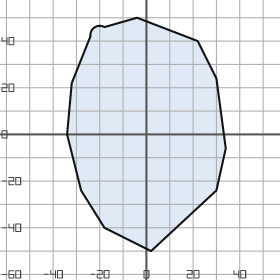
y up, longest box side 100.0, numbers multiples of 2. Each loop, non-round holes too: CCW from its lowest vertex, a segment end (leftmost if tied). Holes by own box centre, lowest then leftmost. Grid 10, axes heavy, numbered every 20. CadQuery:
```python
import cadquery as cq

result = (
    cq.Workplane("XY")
    .moveTo(2.0, -50.0)
    .lineTo(30.0, -24.0)
    .lineTo(34.0, -6.0)
    .lineTo(30.0, 24.0)
    .lineTo(22.0, 40.0)
    .lineTo(-4.0, 50.0)
    .lineTo(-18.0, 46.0)
    .threePointArc((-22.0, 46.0), (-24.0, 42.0))
    .lineTo(-32.0, 22.0)
    .lineTo(-34.0, 0.0)
    .lineTo(-28.0, -24.0)
    .lineTo(-18.0, -40.0)
    .close()
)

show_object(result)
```